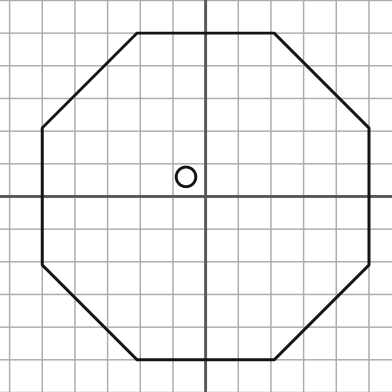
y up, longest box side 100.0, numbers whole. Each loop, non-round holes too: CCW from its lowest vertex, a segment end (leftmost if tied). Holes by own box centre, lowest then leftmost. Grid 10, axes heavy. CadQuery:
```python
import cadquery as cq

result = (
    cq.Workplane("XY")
    .moveTo(-21.0, -50.0)
    .lineTo(21.0, -50.0)
    .lineTo(50.0, -21.0)
    .lineTo(50.0, 21.0)
    .lineTo(21.0, 50.0)
    .lineTo(-21.0, 50.0)
    .lineTo(-50.0, 21.0)
    .lineTo(-50.0, -21.0)
    .close()
    .moveTo(-6.0, 6.0)
    .circle(3.0)
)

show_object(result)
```